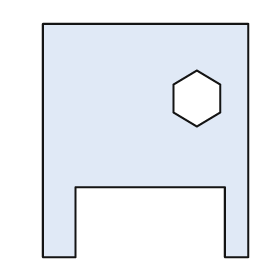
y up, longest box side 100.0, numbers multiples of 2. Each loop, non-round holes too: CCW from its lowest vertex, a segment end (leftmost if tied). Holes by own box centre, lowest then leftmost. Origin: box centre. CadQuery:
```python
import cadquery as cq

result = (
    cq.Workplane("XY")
    .moveTo(-44.0, -50.0)
    .lineTo(-30.0, -50.0)
    .lineTo(-30.0, -20.0)
    .lineTo(34.0, -20.0)
    .lineTo(34.0, -50.0)
    .lineTo(44.0, -50.0)
    .lineTo(44.0, 50.0)
    .lineTo(-44.0, 50.0)
    .close()
    .moveTo(22.0, 6.0)
    .lineTo(32.0, 12.0)
    .lineTo(32.0, 24.0)
    .lineTo(22.0, 30.0)
    .lineTo(12.0, 24.0)
    .lineTo(12.0, 12.0)
    .close()
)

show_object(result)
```